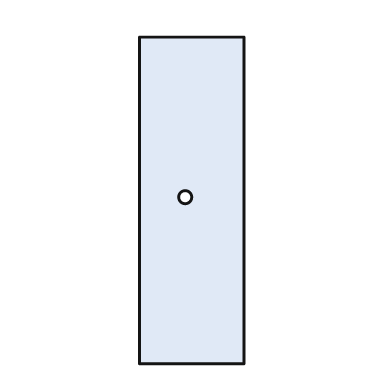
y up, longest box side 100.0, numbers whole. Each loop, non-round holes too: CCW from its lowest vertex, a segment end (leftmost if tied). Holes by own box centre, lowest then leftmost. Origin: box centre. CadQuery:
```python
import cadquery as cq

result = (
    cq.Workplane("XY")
    .moveTo(-16.0, -50.0)
    .lineTo(16.0, -50.0)
    .lineTo(16.0, 50.0)
    .lineTo(-16.0, 50.0)
    .close()
    .moveTo(-2.0, 1.0)
    .circle(2.0)
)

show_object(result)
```